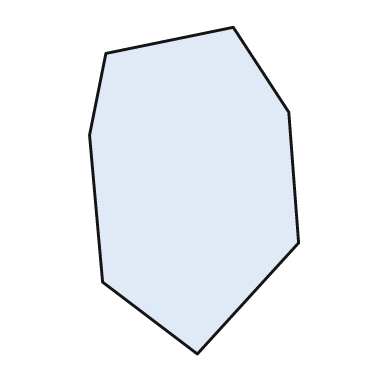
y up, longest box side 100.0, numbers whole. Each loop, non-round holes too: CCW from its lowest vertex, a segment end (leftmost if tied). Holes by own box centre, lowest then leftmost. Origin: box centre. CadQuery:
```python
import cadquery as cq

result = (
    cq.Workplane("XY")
    .moveTo(1.0, -50.0)
    .lineTo(32.0, -16.0)
    .lineTo(29.0, 24.0)
    .lineTo(12.0, 50.0)
    .lineTo(-27.0, 42.0)
    .lineTo(-32.0, 17.0)
    .lineTo(-28.0, -28.0)
    .close()
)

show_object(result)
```